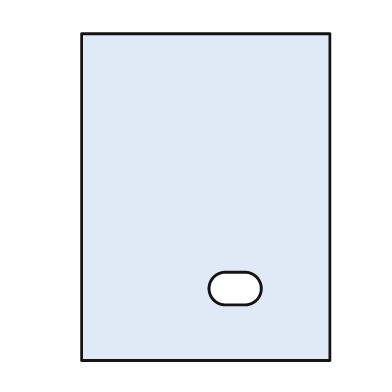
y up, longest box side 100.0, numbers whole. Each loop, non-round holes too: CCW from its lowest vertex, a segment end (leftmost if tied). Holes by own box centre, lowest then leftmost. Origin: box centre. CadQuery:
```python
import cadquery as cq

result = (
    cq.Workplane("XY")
    .moveTo(-38.0, -50.0)
    .lineTo(38.0, -50.0)
    .lineTo(38.0, 50.0)
    .lineTo(-38.0, 50.0)
    .close()
    .moveTo(6.0, -33.0)
    .lineTo(12.0, -33.0)
    .threePointArc((17.0, -28.0), (12.0, -23.0))
    .lineTo(6.0, -23.0)
    .threePointArc((1.0, -28.0), (6.0, -33.0))
    .close()
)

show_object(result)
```